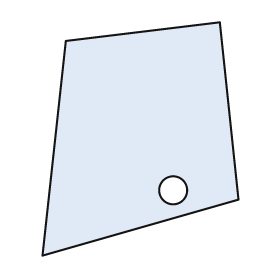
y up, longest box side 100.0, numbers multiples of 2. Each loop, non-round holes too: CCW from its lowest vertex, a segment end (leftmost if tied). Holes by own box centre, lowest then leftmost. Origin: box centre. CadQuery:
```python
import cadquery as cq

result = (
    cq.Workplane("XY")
    .moveTo(-42.0, -50.0)
    .lineTo(42.0, -26.0)
    .lineTo(34.0, 50.0)
    .lineTo(-32.0, 42.0)
    .close()
    .moveTo(14.0, -22.0)
    .circle(6.0)
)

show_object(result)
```